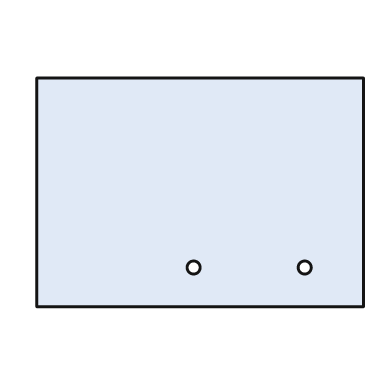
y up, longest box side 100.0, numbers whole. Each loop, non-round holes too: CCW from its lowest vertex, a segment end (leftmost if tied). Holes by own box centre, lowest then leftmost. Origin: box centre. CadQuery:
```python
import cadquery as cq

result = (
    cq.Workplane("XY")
    .moveTo(-50.0, -35.0)
    .lineTo(50.0, -35.0)
    .lineTo(50.0, 35.0)
    .lineTo(-50.0, 35.0)
    .close()
    .moveTo(-2.0, -23.0)
    .circle(2.0)
    .moveTo(32.0, -23.0)
    .circle(2.0)
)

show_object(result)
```